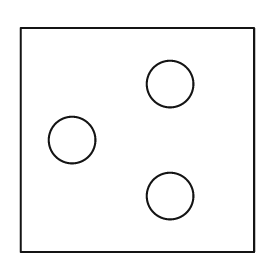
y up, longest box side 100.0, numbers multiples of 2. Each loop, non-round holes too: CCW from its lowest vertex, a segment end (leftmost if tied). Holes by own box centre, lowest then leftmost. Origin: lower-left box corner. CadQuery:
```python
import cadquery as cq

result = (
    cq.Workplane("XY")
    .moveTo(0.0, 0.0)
    .lineTo(100.0, 0.0)
    .lineTo(100.0, 96.0)
    .lineTo(0.0, 96.0)
    .close()
    .moveTo(64.0, 24.0)
    .circle(10.0)
    .moveTo(22.0, 48.0)
    .circle(10.0)
    .moveTo(64.0, 72.0)
    .circle(10.0)
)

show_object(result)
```